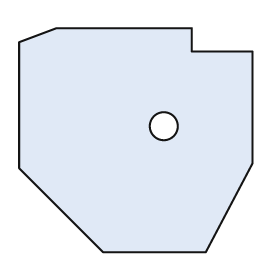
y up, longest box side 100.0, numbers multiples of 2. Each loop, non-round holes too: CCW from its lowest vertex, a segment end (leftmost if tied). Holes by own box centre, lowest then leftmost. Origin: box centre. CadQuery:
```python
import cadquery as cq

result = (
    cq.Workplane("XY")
    .moveTo(-14.0, -48.0)
    .lineTo(30.0, -48.0)
    .lineTo(50.0, -10.0)
    .lineTo(50.0, 38.0)
    .lineTo(24.0, 38.0)
    .lineTo(24.0, 48.0)
    .lineTo(-34.0, 48.0)
    .lineTo(-50.0, 42.0)
    .lineTo(-50.0, -12.0)
    .close()
    .moveTo(12.0, 6.0)
    .circle(6.0)
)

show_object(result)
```